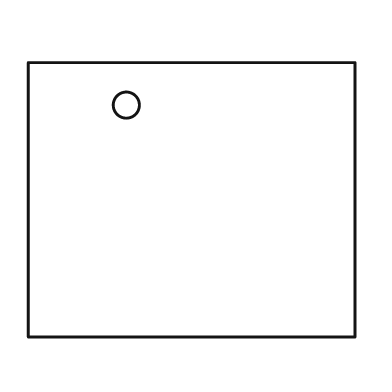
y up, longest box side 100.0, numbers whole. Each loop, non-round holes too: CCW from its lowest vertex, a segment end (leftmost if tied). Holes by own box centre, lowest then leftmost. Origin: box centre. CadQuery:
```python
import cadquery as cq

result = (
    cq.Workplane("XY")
    .moveTo(-50.0, -42.0)
    .lineTo(50.0, -42.0)
    .lineTo(50.0, 42.0)
    .lineTo(-50.0, 42.0)
    .close()
    .moveTo(-20.0, 29.0)
    .circle(4.0)
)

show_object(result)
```